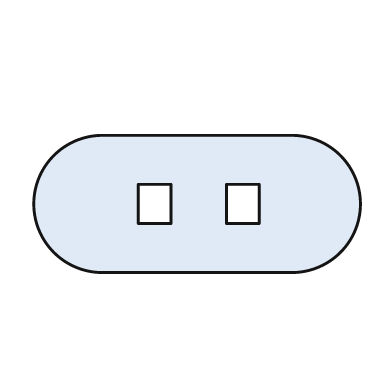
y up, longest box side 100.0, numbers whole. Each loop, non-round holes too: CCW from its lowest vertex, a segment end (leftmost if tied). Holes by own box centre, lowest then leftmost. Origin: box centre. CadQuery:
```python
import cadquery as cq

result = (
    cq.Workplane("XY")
    .moveTo(-29.0, -21.0)
    .lineTo(29.0, -21.0)
    .threePointArc((50.0, 0.0), (29.0, 21.0))
    .lineTo(-29.0, 21.0)
    .threePointArc((-50.0, 0.0), (-29.0, -21.0))
    .close()
    .moveTo(-18.0, -6.0)
    .lineTo(-8.0, -6.0)
    .lineTo(-8.0, 6.0)
    .lineTo(-18.0, 6.0)
    .close()
    .moveTo(9.0, -6.0)
    .lineTo(19.0, -6.0)
    .lineTo(19.0, 6.0)
    .lineTo(9.0, 6.0)
    .close()
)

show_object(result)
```